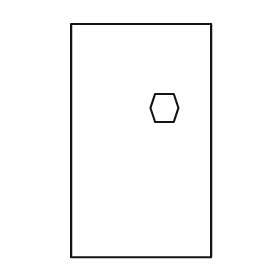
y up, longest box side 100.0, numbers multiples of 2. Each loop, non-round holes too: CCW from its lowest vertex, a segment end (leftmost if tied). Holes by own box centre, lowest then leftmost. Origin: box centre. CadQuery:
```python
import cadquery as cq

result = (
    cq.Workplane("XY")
    .moveTo(-30.0, -50.0)
    .lineTo(30.0, -50.0)
    .lineTo(30.0, 50.0)
    .lineTo(-30.0, 50.0)
    .close()
    .moveTo(6.0, 8.0)
    .lineTo(14.0, 8.0)
    .lineTo(16.0, 14.0)
    .lineTo(14.0, 20.0)
    .lineTo(6.0, 20.0)
    .lineTo(4.0, 14.0)
    .close()
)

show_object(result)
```